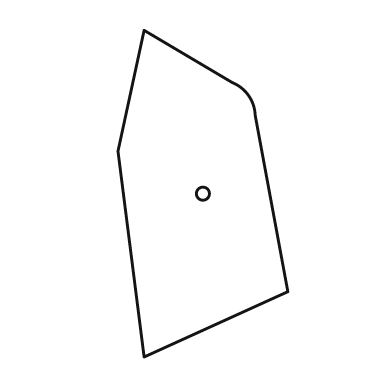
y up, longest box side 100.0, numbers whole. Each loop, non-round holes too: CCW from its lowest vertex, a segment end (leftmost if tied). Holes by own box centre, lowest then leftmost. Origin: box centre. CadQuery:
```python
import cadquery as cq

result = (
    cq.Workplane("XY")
    .moveTo(-18.0, -50.0)
    .lineTo(26.0, -30.0)
    .lineTo(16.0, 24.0)
    .threePointArc((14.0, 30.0), (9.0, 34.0))
    .lineTo(-18.0, 50.0)
    .lineTo(-26.0, 13.0)
    .close()
    .moveTo(0.0, 0.0)
    .circle(2.0)
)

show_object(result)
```